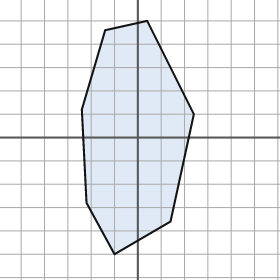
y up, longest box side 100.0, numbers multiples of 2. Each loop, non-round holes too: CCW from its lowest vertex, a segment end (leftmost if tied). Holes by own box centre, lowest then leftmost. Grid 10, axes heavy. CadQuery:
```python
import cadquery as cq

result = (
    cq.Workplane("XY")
    .moveTo(-10.0, -50.0)
    .lineTo(14.0, -36.0)
    .lineTo(24.0, 10.0)
    .lineTo(4.0, 50.0)
    .lineTo(-14.0, 46.0)
    .lineTo(-24.0, 12.0)
    .lineTo(-22.0, -28.0)
    .close()
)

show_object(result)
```